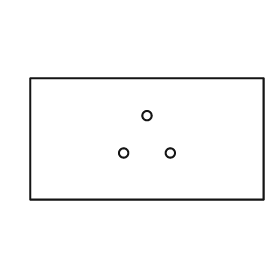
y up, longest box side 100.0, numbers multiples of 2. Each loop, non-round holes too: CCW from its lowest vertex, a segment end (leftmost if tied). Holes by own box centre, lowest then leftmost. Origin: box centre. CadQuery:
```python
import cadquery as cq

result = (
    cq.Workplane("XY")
    .moveTo(-50.0, -26.0)
    .lineTo(50.0, -26.0)
    .lineTo(50.0, 26.0)
    .lineTo(-50.0, 26.0)
    .close()
    .moveTo(-10.0, -6.0)
    .circle(2.0)
    .moveTo(10.0, -6.0)
    .circle(2.0)
    .moveTo(0.0, 10.0)
    .circle(2.0)
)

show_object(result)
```